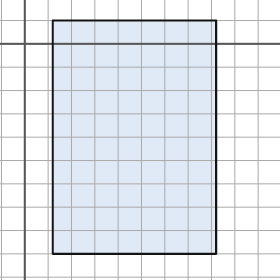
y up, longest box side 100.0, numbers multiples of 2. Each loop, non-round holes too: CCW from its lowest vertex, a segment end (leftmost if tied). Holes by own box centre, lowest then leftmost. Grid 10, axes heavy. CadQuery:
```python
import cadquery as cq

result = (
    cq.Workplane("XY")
    .moveTo(12.0, -90.0)
    .lineTo(82.0, -90.0)
    .lineTo(82.0, 10.0)
    .lineTo(12.0, 10.0)
    .close()
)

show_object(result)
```